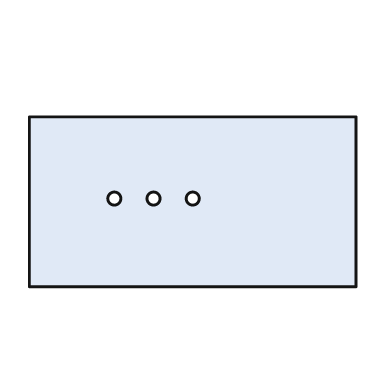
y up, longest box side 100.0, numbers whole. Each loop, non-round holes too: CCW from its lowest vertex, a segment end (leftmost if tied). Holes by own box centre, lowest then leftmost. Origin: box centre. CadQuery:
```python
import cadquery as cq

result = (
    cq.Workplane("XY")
    .moveTo(-50.0, -26.0)
    .lineTo(50.0, -26.0)
    .lineTo(50.0, 26.0)
    .lineTo(-50.0, 26.0)
    .close()
    .moveTo(-24.0, 1.0)
    .circle(2.0)
    .moveTo(-12.0, 1.0)
    .circle(2.0)
    .moveTo(0.0, 1.0)
    .circle(2.0)
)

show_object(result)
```